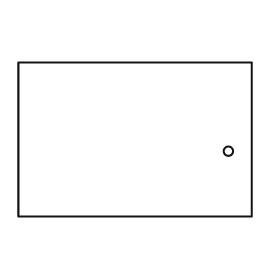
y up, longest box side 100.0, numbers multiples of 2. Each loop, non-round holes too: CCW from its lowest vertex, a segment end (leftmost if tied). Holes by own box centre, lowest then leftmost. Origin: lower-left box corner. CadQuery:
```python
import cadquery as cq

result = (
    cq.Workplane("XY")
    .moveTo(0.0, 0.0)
    .lineTo(100.0, 0.0)
    .lineTo(100.0, 66.0)
    .lineTo(0.0, 66.0)
    .close()
    .moveTo(90.0, 28.0)
    .circle(2.0)
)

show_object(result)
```